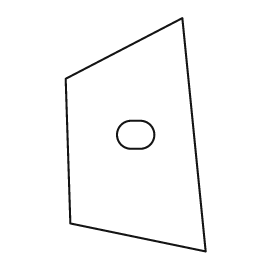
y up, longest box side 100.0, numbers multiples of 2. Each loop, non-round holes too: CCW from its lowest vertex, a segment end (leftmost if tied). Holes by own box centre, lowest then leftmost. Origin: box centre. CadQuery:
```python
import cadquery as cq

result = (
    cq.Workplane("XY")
    .moveTo(30.0, -50.0)
    .lineTo(20.0, 50.0)
    .lineTo(-30.0, 24.0)
    .lineTo(-28.0, -38.0)
    .close()
    .moveTo(-2.0, -6.0)
    .lineTo(2.0, -6.0)
    .threePointArc((8.0, 0.0), (2.0, 6.0))
    .lineTo(-2.0, 6.0)
    .threePointArc((-8.0, 0.0), (-2.0, -6.0))
    .close()
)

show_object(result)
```